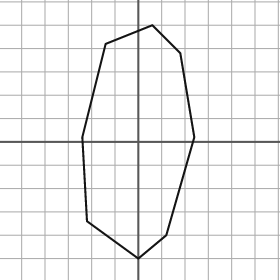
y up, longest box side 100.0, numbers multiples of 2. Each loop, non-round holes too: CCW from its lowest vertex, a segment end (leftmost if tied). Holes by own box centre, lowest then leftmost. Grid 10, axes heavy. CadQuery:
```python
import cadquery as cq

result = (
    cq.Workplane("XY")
    .moveTo(0.0, -50.0)
    .lineTo(12.0, -40.0)
    .lineTo(24.0, 2.0)
    .lineTo(18.0, 38.0)
    .lineTo(6.0, 50.0)
    .lineTo(-14.0, 42.0)
    .lineTo(-24.0, 2.0)
    .lineTo(-22.0, -34.0)
    .close()
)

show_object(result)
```